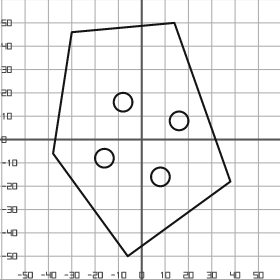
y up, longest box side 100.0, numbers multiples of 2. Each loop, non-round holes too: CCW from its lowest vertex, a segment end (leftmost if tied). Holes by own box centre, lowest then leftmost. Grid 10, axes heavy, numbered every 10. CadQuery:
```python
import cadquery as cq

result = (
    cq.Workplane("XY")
    .moveTo(-6.0, -50.0)
    .lineTo(38.0, -18.0)
    .lineTo(14.0, 50.0)
    .lineTo(-30.0, 46.0)
    .lineTo(-38.0, -6.0)
    .close()
    .moveTo(8.0, -16.0)
    .circle(4.0)
    .moveTo(-16.0, -8.0)
    .circle(4.0)
    .moveTo(16.0, 8.0)
    .circle(4.0)
    .moveTo(-8.0, 16.0)
    .circle(4.0)
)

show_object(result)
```